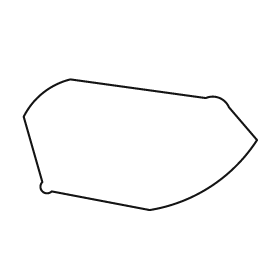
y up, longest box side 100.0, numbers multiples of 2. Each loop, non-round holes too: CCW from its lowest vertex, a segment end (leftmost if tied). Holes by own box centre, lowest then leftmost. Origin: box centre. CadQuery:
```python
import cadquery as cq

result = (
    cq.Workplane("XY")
    .moveTo(4.0, -28.0)
    .threePointArc((30.0, -18.0), (50.0, 2.0))
    .lineTo(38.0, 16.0)
    .threePointArc((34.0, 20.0), (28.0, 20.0))
    .lineTo(-30.0, 28.0)
    .threePointArc((-42.0, 22.0), (-50.0, 12.0))
    .lineTo(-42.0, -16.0)
    .threePointArc((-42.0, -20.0), (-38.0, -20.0))
    .close()
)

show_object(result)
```